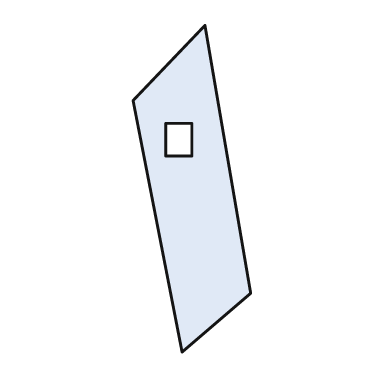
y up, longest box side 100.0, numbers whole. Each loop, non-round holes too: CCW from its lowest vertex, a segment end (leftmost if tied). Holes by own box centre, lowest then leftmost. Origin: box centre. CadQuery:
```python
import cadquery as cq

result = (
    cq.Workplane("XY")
    .moveTo(-3.0, -50.0)
    .lineTo(18.0, -32.0)
    .lineTo(4.0, 50.0)
    .lineTo(-18.0, 27.0)
    .close()
    .moveTo(-8.0, 10.0)
    .lineTo(0.0, 10.0)
    .lineTo(0.0, 20.0)
    .lineTo(-8.0, 20.0)
    .close()
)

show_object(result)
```